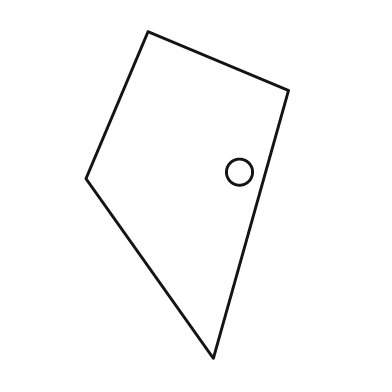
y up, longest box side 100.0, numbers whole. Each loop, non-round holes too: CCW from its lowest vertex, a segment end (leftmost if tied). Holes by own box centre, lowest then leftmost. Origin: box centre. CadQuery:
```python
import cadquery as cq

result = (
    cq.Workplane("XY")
    .moveTo(8.0, -50.0)
    .lineTo(31.0, 32.0)
    .lineTo(-12.0, 50.0)
    .lineTo(-31.0, 5.0)
    .close()
    .moveTo(16.0, 7.0)
    .circle(4.0)
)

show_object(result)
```